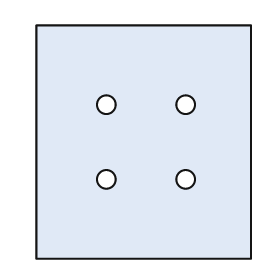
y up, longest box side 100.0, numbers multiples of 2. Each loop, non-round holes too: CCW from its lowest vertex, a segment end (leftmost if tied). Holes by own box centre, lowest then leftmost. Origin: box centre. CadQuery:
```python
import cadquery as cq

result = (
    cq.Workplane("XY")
    .moveTo(-46.0, -50.0)
    .lineTo(46.0, -50.0)
    .lineTo(46.0, 50.0)
    .lineTo(-46.0, 50.0)
    .close()
    .moveTo(-16.0, -16.0)
    .circle(4.0)
    .moveTo(18.0, -16.0)
    .circle(4.0)
    .moveTo(-16.0, 16.0)
    .circle(4.0)
    .moveTo(18.0, 16.0)
    .circle(4.0)
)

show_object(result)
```